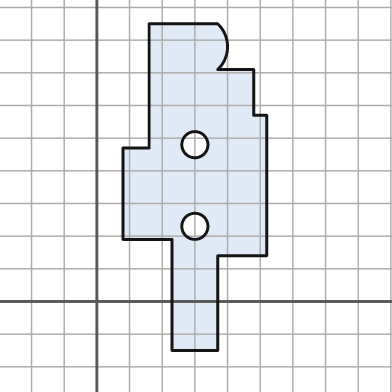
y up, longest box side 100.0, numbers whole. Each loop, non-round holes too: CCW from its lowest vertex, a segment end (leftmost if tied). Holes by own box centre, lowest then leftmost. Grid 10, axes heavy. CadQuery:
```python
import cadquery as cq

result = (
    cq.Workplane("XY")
    .moveTo(23.0, -15.0)
    .lineTo(37.0, -15.0)
    .lineTo(37.0, 14.0)
    .lineTo(52.0, 14.0)
    .lineTo(52.0, 57.0)
    .lineTo(48.0, 57.0)
    .lineTo(48.0, 71.0)
    .lineTo(37.0, 71.0)
    .threePointArc((40.0, 78.0), (37.0, 85.0))
    .lineTo(16.0, 85.0)
    .lineTo(16.0, 47.0)
    .lineTo(8.0, 47.0)
    .lineTo(8.0, 19.0)
    .lineTo(23.0, 19.0)
    .close()
    .moveTo(30.0, 23.0)
    .circle(4.0)
    .moveTo(30.0, 48.0)
    .circle(4.0)
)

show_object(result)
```